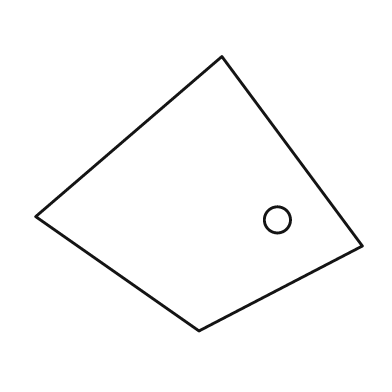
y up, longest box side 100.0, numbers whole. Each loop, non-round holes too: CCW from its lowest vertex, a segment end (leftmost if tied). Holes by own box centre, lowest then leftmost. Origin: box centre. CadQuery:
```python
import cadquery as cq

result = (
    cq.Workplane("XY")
    .moveTo(0.0, -42.0)
    .lineTo(50.0, -16.0)
    .lineTo(7.0, 42.0)
    .lineTo(-50.0, -7.0)
    .close()
    .moveTo(24.0, -8.0)
    .circle(4.0)
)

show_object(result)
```